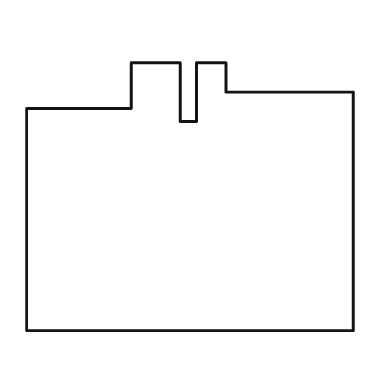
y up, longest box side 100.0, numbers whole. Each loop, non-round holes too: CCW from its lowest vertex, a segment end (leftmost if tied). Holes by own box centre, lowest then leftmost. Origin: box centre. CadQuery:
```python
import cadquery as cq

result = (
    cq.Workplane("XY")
    .moveTo(-50.0, -41.0)
    .lineTo(50.0, -41.0)
    .lineTo(50.0, 32.0)
    .lineTo(11.0, 32.0)
    .lineTo(11.0, 41.0)
    .lineTo(2.0, 41.0)
    .lineTo(2.0, 23.0)
    .lineTo(-3.0, 23.0)
    .lineTo(-3.0, 41.0)
    .lineTo(-18.0, 41.0)
    .lineTo(-18.0, 27.0)
    .lineTo(-50.0, 27.0)
    .close()
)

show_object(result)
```